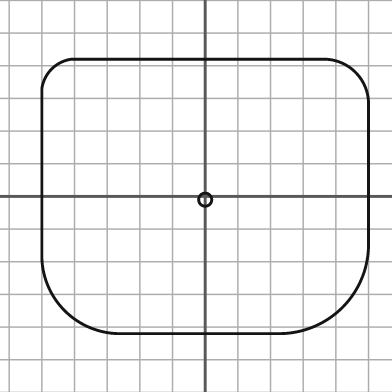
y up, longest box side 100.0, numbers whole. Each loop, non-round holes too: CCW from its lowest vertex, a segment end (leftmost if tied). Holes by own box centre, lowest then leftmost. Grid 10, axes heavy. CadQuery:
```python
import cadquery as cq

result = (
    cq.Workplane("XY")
    .moveTo(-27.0, -42.0)
    .lineTo(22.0, -42.0)
    .threePointArc((42.0, -34.0), (50.0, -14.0))
    .lineTo(50.0, 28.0)
    .threePointArc((46.0, 38.0), (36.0, 42.0))
    .lineTo(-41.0, 42.0)
    .threePointArc((-47.0, 39.0), (-50.0, 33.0))
    .lineTo(-50.0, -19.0)
    .threePointArc((-43.0, -35.0), (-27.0, -42.0))
    .close()
    .moveTo(0.0, -1.0)
    .circle(2.0)
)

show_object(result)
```